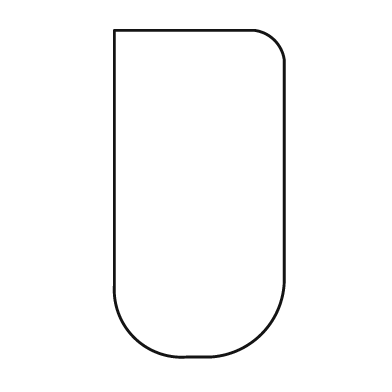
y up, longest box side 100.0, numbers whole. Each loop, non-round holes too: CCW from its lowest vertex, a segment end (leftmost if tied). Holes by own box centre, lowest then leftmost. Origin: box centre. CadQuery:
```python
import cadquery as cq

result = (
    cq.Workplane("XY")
    .moveTo(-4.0, -50.0)
    .lineTo(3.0, -50.0)
    .threePointArc((19.0, -43.0), (26.0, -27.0))
    .lineTo(26.0, 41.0)
    .threePointArc((23.0, 47.0), (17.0, 50.0))
    .lineTo(-26.0, 50.0)
    .lineTo(-26.0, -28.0)
    .threePointArc((-20.0, -44.0), (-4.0, -50.0))
    .close()
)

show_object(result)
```